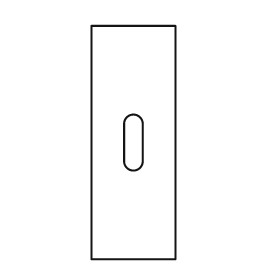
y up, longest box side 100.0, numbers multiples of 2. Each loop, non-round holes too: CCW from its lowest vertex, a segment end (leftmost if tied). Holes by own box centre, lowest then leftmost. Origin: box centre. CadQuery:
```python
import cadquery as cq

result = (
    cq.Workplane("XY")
    .moveTo(-18.0, -50.0)
    .lineTo(18.0, -50.0)
    .lineTo(18.0, 50.0)
    .lineTo(-18.0, 50.0)
    .close()
    .moveTo(-4.0, -8.0)
    .threePointArc((0.0, -12.0), (4.0, -8.0))
    .lineTo(4.0, 8.0)
    .threePointArc((0.0, 12.0), (-4.0, 8.0))
    .close()
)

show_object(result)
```